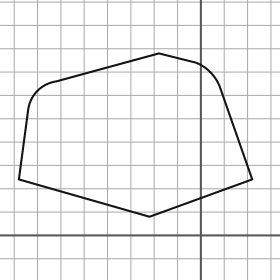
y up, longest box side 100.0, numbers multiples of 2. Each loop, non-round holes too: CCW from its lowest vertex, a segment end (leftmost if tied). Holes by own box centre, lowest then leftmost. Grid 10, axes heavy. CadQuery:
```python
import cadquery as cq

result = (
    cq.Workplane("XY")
    .moveTo(-22.0, 8.0)
    .lineTo(22.0, 24.0)
    .lineTo(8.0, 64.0)
    .threePointArc((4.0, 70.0), (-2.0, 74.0))
    .lineTo(-18.0, 78.0)
    .lineTo(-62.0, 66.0)
    .threePointArc((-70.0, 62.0), (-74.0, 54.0))
    .lineTo(-78.0, 24.0)
    .close()
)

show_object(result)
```